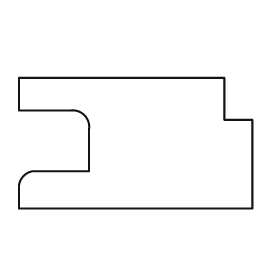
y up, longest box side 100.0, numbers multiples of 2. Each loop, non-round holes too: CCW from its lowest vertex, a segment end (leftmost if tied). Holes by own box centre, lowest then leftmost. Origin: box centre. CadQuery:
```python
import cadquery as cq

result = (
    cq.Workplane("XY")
    .moveTo(-50.0, -28.0)
    .lineTo(50.0, -28.0)
    .lineTo(50.0, 10.0)
    .lineTo(38.0, 10.0)
    .lineTo(38.0, 28.0)
    .lineTo(-50.0, 28.0)
    .lineTo(-50.0, 14.0)
    .lineTo(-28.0, 14.0)
    .threePointArc((-22.0, 12.0), (-20.0, 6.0))
    .lineTo(-20.0, -12.0)
    .lineTo(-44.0, -12.0)
    .threePointArc((-48.0, -14.0), (-50.0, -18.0))
    .close()
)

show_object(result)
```